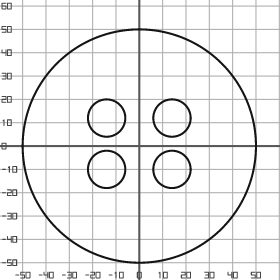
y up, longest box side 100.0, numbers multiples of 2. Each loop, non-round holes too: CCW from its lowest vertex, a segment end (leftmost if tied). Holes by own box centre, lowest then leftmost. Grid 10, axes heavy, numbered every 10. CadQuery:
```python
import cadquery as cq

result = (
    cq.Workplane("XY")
    .moveTo(0.0, 0.0)
    .circle(50.0)
    .moveTo(-14.0, -10.0)
    .circle(8.0)
    .moveTo(14.0, -10.0)
    .circle(8.0)
    .moveTo(-14.0, 12.0)
    .circle(8.0)
    .moveTo(14.0, 12.0)
    .circle(8.0)
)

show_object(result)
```